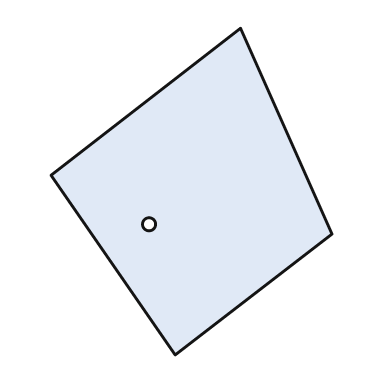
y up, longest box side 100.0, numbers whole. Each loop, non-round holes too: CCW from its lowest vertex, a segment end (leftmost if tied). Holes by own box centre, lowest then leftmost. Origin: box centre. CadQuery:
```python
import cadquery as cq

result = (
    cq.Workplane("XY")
    .moveTo(-5.0, -50.0)
    .lineTo(43.0, -13.0)
    .lineTo(15.0, 50.0)
    .lineTo(-43.0, 5.0)
    .close()
    .moveTo(-13.0, -10.0)
    .circle(2.0)
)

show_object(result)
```